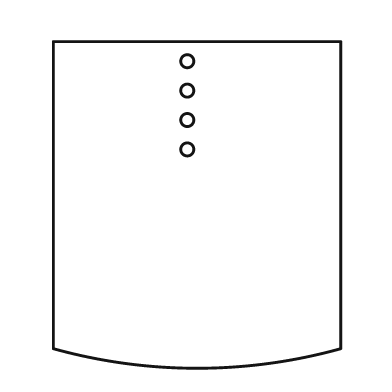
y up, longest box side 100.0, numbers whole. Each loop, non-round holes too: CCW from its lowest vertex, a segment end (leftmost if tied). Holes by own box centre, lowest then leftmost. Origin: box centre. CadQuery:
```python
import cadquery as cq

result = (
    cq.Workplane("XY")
    .moveTo(-44.0, -44.0)
    .threePointArc((0.0, -50.0), (44.0, -44.0))
    .lineTo(44.0, 50.0)
    .lineTo(-44.0, 50.0)
    .close()
    .moveTo(-3.0, 17.0)
    .circle(2.0)
    .moveTo(-3.0, 26.0)
    .circle(2.0)
    .moveTo(-3.0, 35.0)
    .circle(2.0)
    .moveTo(-3.0, 44.0)
    .circle(2.0)
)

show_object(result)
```